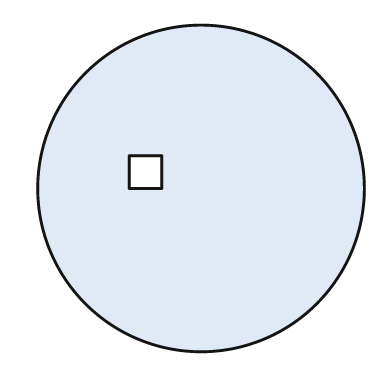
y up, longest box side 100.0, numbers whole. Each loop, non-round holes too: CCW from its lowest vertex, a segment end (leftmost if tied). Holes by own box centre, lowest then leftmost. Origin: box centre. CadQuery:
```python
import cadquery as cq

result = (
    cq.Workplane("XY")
    .moveTo(0.0, 0.0)
    .circle(50.0)
    .moveTo(-22.0, 0.0)
    .lineTo(-12.0, 0.0)
    .lineTo(-12.0, 10.0)
    .lineTo(-22.0, 10.0)
    .close()
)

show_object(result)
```